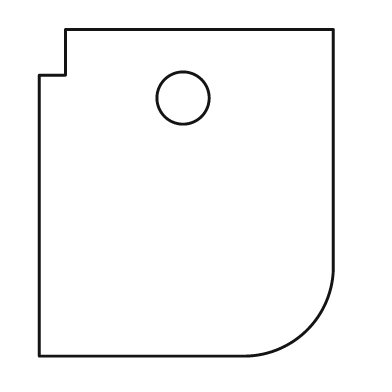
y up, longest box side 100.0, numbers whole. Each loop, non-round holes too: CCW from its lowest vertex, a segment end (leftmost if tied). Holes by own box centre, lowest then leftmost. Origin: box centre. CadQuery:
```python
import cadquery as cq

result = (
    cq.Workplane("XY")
    .moveTo(-45.0, -50.0)
    .lineTo(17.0, -50.0)
    .threePointArc((37.0, -42.0), (45.0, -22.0))
    .lineTo(45.0, 50.0)
    .lineTo(-37.0, 50.0)
    .lineTo(-37.0, 36.0)
    .lineTo(-45.0, 36.0)
    .close()
    .moveTo(-1.0, 29.0)
    .circle(8.0)
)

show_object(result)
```